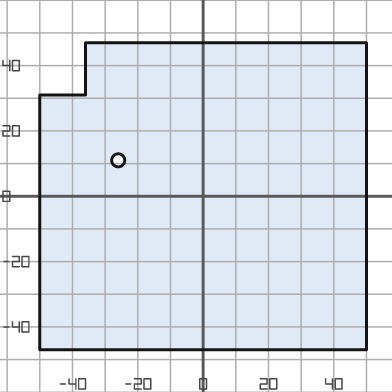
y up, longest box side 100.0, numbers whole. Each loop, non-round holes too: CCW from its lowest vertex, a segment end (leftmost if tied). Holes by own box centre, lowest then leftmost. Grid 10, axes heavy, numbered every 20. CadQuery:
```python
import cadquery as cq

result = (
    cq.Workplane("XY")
    .moveTo(-50.0, -47.0)
    .lineTo(50.0, -47.0)
    .lineTo(50.0, 47.0)
    .lineTo(-36.0, 47.0)
    .lineTo(-36.0, 31.0)
    .lineTo(-50.0, 31.0)
    .close()
    .moveTo(-26.0, 11.0)
    .circle(2.0)
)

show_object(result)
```